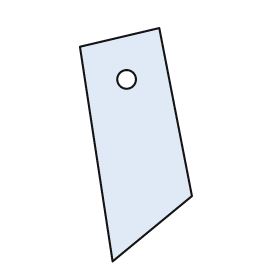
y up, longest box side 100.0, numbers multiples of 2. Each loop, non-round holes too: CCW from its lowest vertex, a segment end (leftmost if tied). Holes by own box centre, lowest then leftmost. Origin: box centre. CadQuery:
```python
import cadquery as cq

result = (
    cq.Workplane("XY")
    .moveTo(-10.0, -50.0)
    .lineTo(24.0, -22.0)
    .lineTo(10.0, 50.0)
    .lineTo(-24.0, 42.0)
    .close()
    .moveTo(-4.0, 28.0)
    .circle(4.0)
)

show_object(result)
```